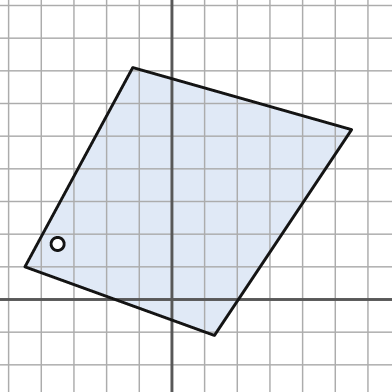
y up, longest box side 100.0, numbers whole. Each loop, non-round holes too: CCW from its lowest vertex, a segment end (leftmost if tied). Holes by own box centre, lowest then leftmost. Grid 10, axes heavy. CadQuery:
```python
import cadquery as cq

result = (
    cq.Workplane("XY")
    .moveTo(13.0, -11.0)
    .lineTo(55.0, 52.0)
    .lineTo(-12.0, 71.0)
    .lineTo(-45.0, 10.0)
    .close()
    .moveTo(-35.0, 17.0)
    .circle(2.0)
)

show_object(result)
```